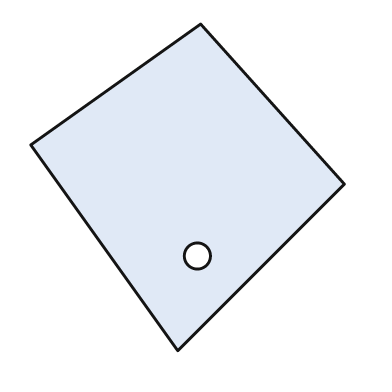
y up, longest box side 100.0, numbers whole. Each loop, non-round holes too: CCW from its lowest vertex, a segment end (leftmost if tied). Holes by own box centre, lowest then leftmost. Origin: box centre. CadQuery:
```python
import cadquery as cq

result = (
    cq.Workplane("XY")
    .moveTo(-3.0, -50.0)
    .lineTo(48.0, 1.0)
    .lineTo(4.0, 50.0)
    .lineTo(-48.0, 13.0)
    .close()
    .moveTo(3.0, -21.0)
    .circle(4.0)
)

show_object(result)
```